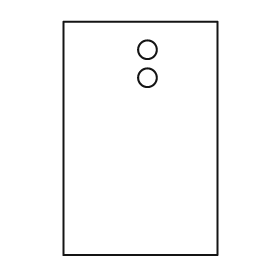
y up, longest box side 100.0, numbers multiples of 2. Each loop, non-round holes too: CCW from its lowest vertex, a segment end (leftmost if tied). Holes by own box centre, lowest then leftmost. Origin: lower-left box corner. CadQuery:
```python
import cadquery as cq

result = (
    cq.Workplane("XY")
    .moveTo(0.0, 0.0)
    .lineTo(66.0, 0.0)
    .lineTo(66.0, 100.0)
    .lineTo(0.0, 100.0)
    .close()
    .moveTo(36.0, 76.0)
    .circle(4.0)
    .moveTo(36.0, 88.0)
    .circle(4.0)
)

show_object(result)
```